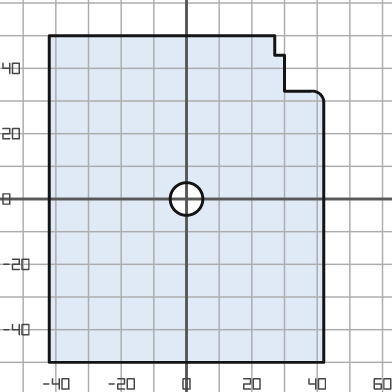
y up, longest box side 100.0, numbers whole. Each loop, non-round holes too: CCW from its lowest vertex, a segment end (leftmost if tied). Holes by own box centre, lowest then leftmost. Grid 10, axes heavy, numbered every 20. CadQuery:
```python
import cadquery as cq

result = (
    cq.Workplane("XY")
    .moveTo(-42.0, -50.0)
    .lineTo(42.0, -50.0)
    .lineTo(42.0, 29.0)
    .threePointArc((41.0, 32.0), (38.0, 33.0))
    .lineTo(30.0, 33.0)
    .lineTo(30.0, 44.0)
    .lineTo(27.0, 44.0)
    .lineTo(27.0, 50.0)
    .lineTo(-42.0, 50.0)
    .close()
    .moveTo(0.0, 0.0)
    .circle(5.0)
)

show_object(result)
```